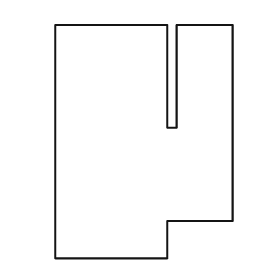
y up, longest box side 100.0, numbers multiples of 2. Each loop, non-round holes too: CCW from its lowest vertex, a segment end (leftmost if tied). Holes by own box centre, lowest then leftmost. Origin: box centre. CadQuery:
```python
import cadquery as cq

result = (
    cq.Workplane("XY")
    .moveTo(-38.0, -50.0)
    .lineTo(10.0, -50.0)
    .lineTo(10.0, -34.0)
    .lineTo(38.0, -34.0)
    .lineTo(38.0, 50.0)
    .lineTo(14.0, 50.0)
    .lineTo(14.0, 6.0)
    .lineTo(10.0, 6.0)
    .lineTo(10.0, 50.0)
    .lineTo(-38.0, 50.0)
    .close()
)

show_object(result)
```